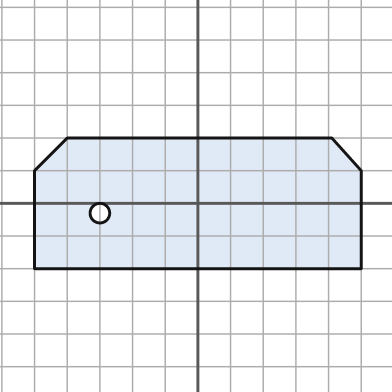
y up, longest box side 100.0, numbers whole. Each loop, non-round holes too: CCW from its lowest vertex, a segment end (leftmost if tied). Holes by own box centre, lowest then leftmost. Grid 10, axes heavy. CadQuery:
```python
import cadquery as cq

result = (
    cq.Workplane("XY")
    .moveTo(-50.0, -20.0)
    .lineTo(50.0, -20.0)
    .lineTo(50.0, 10.0)
    .lineTo(41.0, 20.0)
    .lineTo(-40.0, 20.0)
    .lineTo(-50.0, 10.0)
    .close()
    .moveTo(-30.0, -3.0)
    .circle(3.0)
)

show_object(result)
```